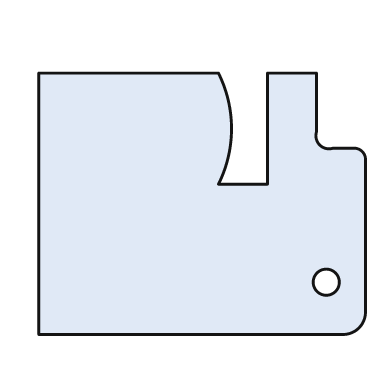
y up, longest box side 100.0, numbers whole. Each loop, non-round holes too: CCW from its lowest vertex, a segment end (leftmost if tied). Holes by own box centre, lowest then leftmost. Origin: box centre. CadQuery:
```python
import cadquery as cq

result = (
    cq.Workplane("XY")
    .moveTo(-50.0, -40.0)
    .lineTo(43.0, -40.0)
    .threePointArc((48.0, -38.0), (50.0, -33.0))
    .lineTo(50.0, 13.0)
    .threePointArc((49.0, 16.0), (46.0, 17.0))
    .lineTo(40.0, 17.0)
    .threePointArc((36.0, 18.0), (35.0, 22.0))
    .lineTo(35.0, 40.0)
    .lineTo(20.0, 40.0)
    .lineTo(20.0, 6.0)
    .lineTo(5.0, 6.0)
    .threePointArc((9.0, 23.0), (5.0, 40.0))
    .lineTo(-50.0, 40.0)
    .close()
    .moveTo(38.0, -24.0)
    .circle(4.0)
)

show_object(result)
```